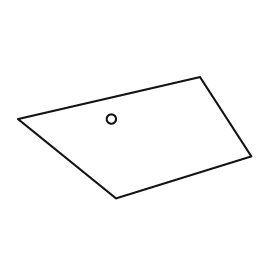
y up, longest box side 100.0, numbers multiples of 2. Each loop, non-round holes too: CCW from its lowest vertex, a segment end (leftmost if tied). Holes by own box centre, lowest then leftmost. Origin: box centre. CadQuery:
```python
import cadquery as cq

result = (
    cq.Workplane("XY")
    .moveTo(-8.0, -26.0)
    .lineTo(50.0, -8.0)
    .lineTo(28.0, 26.0)
    .lineTo(-50.0, 8.0)
    .close()
    .moveTo(-10.0, 8.0)
    .circle(2.0)
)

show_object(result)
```